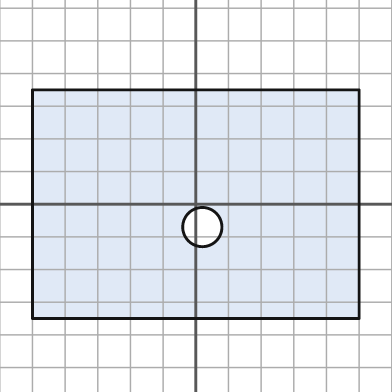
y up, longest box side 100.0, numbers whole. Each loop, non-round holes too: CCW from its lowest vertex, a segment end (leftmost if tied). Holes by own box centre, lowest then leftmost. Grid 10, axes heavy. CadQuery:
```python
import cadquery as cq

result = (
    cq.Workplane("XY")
    .moveTo(-50.0, -35.0)
    .lineTo(50.0, -35.0)
    .lineTo(50.0, 35.0)
    .lineTo(-50.0, 35.0)
    .close()
    .moveTo(2.0, -7.0)
    .circle(6.0)
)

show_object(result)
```